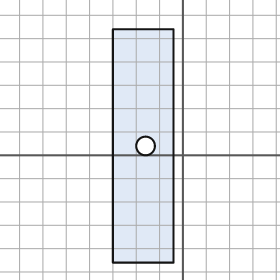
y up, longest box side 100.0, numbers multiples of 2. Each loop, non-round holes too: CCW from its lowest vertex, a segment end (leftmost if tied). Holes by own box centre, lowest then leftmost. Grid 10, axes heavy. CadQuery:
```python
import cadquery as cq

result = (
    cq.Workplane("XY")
    .moveTo(-30.0, -46.0)
    .lineTo(-4.0, -46.0)
    .lineTo(-4.0, 54.0)
    .lineTo(-30.0, 54.0)
    .close()
    .moveTo(-16.0, 4.0)
    .circle(4.0)
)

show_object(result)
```